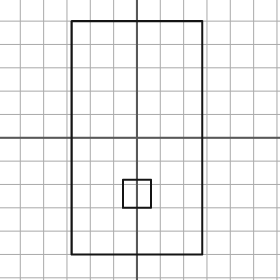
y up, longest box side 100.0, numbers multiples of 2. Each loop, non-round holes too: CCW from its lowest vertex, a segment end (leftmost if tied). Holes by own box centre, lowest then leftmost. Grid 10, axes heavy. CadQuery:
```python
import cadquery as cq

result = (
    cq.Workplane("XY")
    .moveTo(-28.0, -50.0)
    .lineTo(28.0, -50.0)
    .lineTo(28.0, 50.0)
    .lineTo(-28.0, 50.0)
    .close()
    .moveTo(-6.0, -30.0)
    .lineTo(6.0, -30.0)
    .lineTo(6.0, -18.0)
    .lineTo(-6.0, -18.0)
    .close()
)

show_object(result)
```